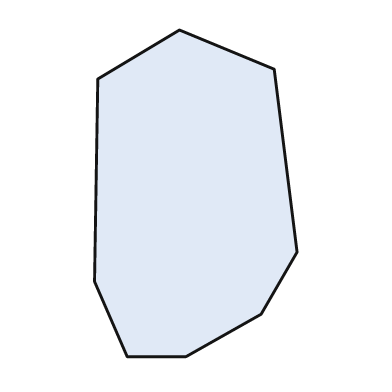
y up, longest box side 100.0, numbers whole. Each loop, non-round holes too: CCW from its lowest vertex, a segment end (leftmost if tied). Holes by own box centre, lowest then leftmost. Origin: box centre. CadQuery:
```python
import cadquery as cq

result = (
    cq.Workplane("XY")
    .moveTo(-21.0, -50.0)
    .lineTo(-3.0, -50.0)
    .lineTo(20.0, -37.0)
    .lineTo(31.0, -18.0)
    .lineTo(24.0, 38.0)
    .lineTo(-5.0, 50.0)
    .lineTo(-30.0, 35.0)
    .lineTo(-31.0, -27.0)
    .close()
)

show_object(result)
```